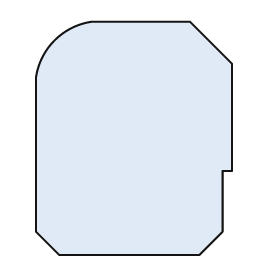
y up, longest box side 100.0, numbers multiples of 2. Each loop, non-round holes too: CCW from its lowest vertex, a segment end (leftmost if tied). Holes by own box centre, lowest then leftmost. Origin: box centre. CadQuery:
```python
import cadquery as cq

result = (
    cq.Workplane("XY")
    .moveTo(-32.0, -50.0)
    .lineTo(28.0, -50.0)
    .lineTo(38.0, -40.0)
    .lineTo(38.0, -14.0)
    .lineTo(42.0, -14.0)
    .lineTo(42.0, 32.0)
    .lineTo(24.0, 50.0)
    .lineTo(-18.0, 50.0)
    .threePointArc((-34.0, 42.0), (-42.0, 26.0))
    .lineTo(-42.0, -40.0)
    .close()
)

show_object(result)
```